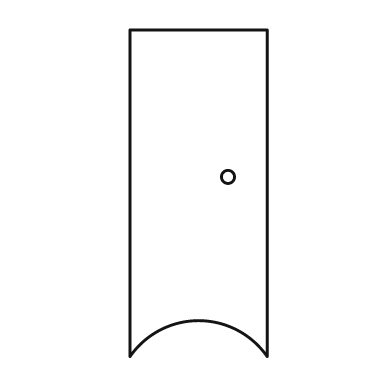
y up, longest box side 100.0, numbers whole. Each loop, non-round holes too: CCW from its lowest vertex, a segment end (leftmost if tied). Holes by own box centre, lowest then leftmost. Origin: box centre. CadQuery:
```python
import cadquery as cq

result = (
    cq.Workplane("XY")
    .moveTo(-21.0, -50.0)
    .threePointArc((0.0, -39.0), (21.0, -50.0))
    .lineTo(21.0, 50.0)
    .lineTo(-21.0, 50.0)
    .close()
    .moveTo(9.0, 5.0)
    .circle(2.0)
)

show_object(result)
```